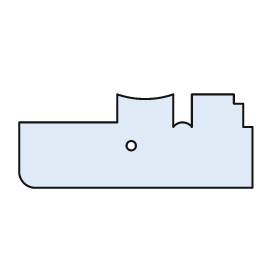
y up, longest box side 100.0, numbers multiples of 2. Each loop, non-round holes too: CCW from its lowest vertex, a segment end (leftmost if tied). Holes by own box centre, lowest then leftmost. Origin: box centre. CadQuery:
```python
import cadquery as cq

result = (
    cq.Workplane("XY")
    .moveTo(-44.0, -20.0)
    .lineTo(50.0, -20.0)
    .lineTo(50.0, 6.0)
    .lineTo(46.0, 6.0)
    .lineTo(46.0, 16.0)
    .lineTo(42.0, 16.0)
    .lineTo(42.0, 20.0)
    .lineTo(24.0, 20.0)
    .lineTo(24.0, 6.0)
    .threePointArc((20.0, 8.0), (16.0, 6.0))
    .lineTo(16.0, 20.0)
    .threePointArc((4.0, 18.0), (-8.0, 20.0))
    .lineTo(-8.0, 8.0)
    .lineTo(-50.0, 8.0)
    .lineTo(-50.0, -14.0)
    .threePointArc((-48.0, -18.0), (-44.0, -20.0))
    .close()
    .moveTo(-2.0, -2.0)
    .circle(2.0)
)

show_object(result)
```